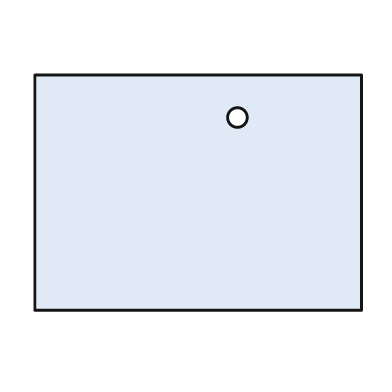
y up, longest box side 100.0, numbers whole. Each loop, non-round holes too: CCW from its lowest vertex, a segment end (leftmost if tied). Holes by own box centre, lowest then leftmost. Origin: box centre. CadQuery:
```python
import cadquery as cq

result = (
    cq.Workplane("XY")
    .moveTo(-50.0, -36.0)
    .lineTo(50.0, -36.0)
    .lineTo(50.0, 36.0)
    .lineTo(-50.0, 36.0)
    .close()
    .moveTo(12.0, 23.0)
    .circle(3.0)
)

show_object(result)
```